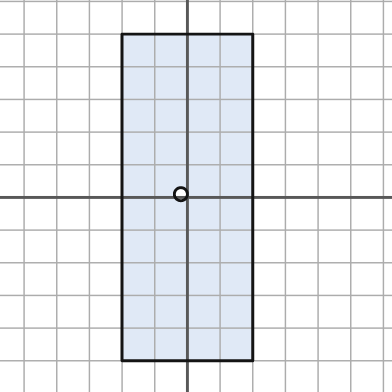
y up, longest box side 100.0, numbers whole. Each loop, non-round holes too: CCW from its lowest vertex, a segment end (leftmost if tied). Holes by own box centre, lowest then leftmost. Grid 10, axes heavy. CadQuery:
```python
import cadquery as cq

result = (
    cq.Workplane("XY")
    .moveTo(-20.0, -50.0)
    .lineTo(20.0, -50.0)
    .lineTo(20.0, 50.0)
    .lineTo(-20.0, 50.0)
    .close()
    .moveTo(-2.0, 1.0)
    .circle(2.0)
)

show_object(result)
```